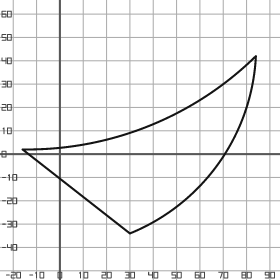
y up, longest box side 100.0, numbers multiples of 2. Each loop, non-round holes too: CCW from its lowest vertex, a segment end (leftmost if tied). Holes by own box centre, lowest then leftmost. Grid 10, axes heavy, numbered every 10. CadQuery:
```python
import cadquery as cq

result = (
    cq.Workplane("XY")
    .moveTo(30.0, -34.0)
    .threePointArc((68.0, -4.0), (84.0, 42.0))
    .threePointArc((38.0, 12.0), (-16.0, 2.0))
    .close()
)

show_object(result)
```